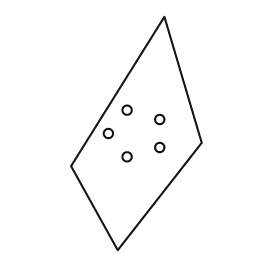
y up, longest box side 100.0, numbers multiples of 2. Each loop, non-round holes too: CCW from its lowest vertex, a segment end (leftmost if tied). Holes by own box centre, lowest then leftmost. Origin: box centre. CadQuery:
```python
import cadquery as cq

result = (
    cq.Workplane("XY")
    .moveTo(-8.0, -50.0)
    .lineTo(28.0, -4.0)
    .lineTo(12.0, 50.0)
    .lineTo(-28.0, -14.0)
    .close()
    .moveTo(-4.0, -10.0)
    .circle(2.0)
    .moveTo(10.0, -6.0)
    .circle(2.0)
    .moveTo(-12.0, 0.0)
    .circle(2.0)
    .moveTo(10.0, 6.0)
    .circle(2.0)
    .moveTo(-4.0, 10.0)
    .circle(2.0)
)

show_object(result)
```